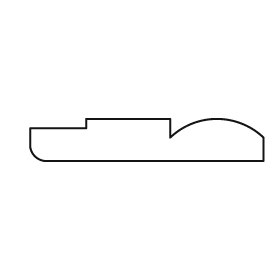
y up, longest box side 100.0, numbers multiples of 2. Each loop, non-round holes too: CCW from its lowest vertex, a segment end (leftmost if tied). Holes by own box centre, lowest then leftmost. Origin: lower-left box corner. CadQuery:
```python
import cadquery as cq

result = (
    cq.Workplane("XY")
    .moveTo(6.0, 0.0)
    .lineTo(100.0, 0.0)
    .lineTo(100.0, 10.0)
    .threePointArc((80.0, 18.0), (60.0, 10.0))
    .lineTo(60.0, 18.0)
    .lineTo(24.0, 18.0)
    .lineTo(24.0, 14.0)
    .lineTo(0.0, 14.0)
    .lineTo(0.0, 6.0)
    .threePointArc((2.0, 2.0), (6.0, 0.0))
    .close()
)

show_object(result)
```